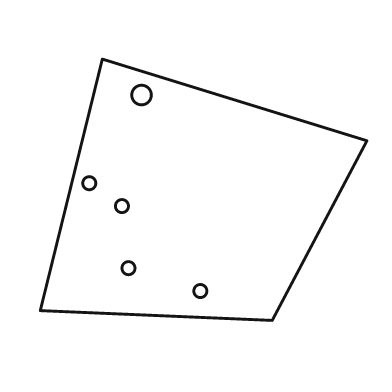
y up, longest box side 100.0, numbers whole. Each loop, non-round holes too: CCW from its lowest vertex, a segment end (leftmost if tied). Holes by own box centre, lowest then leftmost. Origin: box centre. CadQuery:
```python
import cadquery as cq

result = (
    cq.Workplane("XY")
    .moveTo(21.0, -40.0)
    .lineTo(50.0, 15.0)
    .lineTo(-31.0, 40.0)
    .lineTo(-50.0, -37.0)
    .close()
    .moveTo(-1.0, -31.0)
    .circle(2.0)
    .moveTo(-23.0, -24.0)
    .circle(2.0)
    .moveTo(-25.0, -5.0)
    .circle(2.0)
    .moveTo(-35.0, 2.0)
    .circle(2.0)
    .moveTo(-19.0, 29.0)
    .circle(3.0)
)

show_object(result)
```